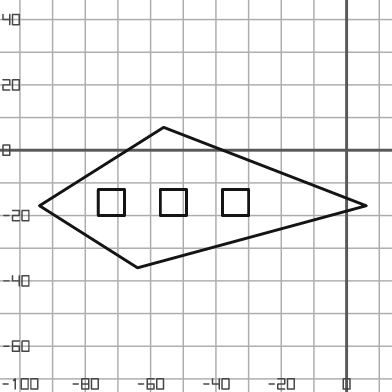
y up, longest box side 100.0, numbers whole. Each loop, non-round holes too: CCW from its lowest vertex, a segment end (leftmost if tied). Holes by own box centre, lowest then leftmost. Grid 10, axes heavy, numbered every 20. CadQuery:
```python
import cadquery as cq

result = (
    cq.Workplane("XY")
    .moveTo(-64.0, -36.0)
    .lineTo(6.0, -17.0)
    .lineTo(-56.0, 7.0)
    .lineTo(-94.0, -17.0)
    .close()
    .moveTo(-76.0, -20.0)
    .lineTo(-68.0, -20.0)
    .lineTo(-68.0, -12.0)
    .lineTo(-76.0, -12.0)
    .close()
    .moveTo(-57.0, -20.0)
    .lineTo(-49.0, -20.0)
    .lineTo(-49.0, -12.0)
    .lineTo(-57.0, -12.0)
    .close()
    .moveTo(-38.0, -20.0)
    .lineTo(-30.0, -20.0)
    .lineTo(-30.0, -12.0)
    .lineTo(-38.0, -12.0)
    .close()
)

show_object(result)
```